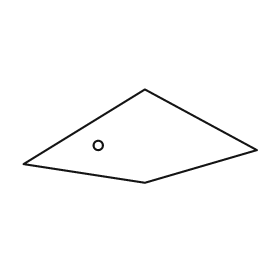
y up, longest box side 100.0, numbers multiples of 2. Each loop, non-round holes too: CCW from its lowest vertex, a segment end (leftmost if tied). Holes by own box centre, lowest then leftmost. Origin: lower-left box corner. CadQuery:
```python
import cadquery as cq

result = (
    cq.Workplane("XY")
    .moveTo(52.0, 0.0)
    .lineTo(100.0, 14.0)
    .lineTo(52.0, 40.0)
    .lineTo(0.0, 8.0)
    .close()
    .moveTo(32.0, 16.0)
    .circle(2.0)
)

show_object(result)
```